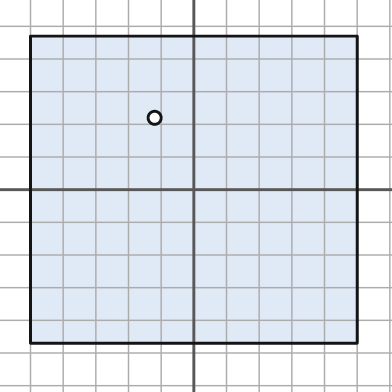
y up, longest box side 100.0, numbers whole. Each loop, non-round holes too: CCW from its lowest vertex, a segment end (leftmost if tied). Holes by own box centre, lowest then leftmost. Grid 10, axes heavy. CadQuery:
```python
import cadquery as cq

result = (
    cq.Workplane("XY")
    .moveTo(-50.0, -47.0)
    .lineTo(50.0, -47.0)
    .lineTo(50.0, 47.0)
    .lineTo(-50.0, 47.0)
    .close()
    .moveTo(-12.0, 22.0)
    .circle(2.0)
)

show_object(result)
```